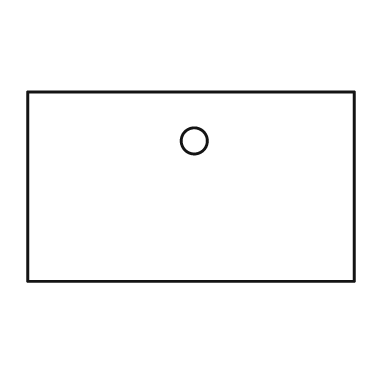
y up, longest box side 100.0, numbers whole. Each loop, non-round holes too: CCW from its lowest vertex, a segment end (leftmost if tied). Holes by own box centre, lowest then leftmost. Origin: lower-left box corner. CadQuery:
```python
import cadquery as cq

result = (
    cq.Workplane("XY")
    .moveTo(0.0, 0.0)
    .lineTo(100.0, 0.0)
    .lineTo(100.0, 58.0)
    .lineTo(0.0, 58.0)
    .close()
    .moveTo(51.0, 43.0)
    .circle(4.0)
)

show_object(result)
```